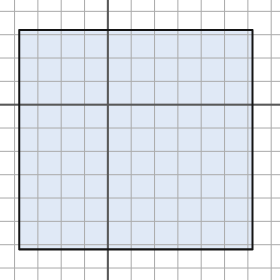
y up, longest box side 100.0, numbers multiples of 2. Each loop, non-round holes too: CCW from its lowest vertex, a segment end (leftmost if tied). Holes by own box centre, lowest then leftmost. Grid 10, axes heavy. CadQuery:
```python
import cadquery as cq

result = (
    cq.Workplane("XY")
    .moveTo(-38.0, -62.0)
    .lineTo(62.0, -62.0)
    .lineTo(62.0, 32.0)
    .lineTo(-38.0, 32.0)
    .close()
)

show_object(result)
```